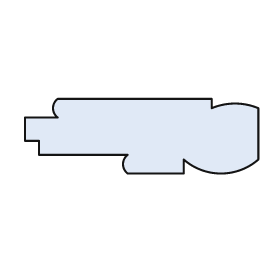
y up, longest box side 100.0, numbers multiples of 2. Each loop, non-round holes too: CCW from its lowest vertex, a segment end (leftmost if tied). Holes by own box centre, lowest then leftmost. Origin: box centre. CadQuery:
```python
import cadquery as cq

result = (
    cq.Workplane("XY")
    .moveTo(-6.0, -16.0)
    .lineTo(18.0, -16.0)
    .lineTo(18.0, -10.0)
    .threePointArc((34.0, -16.0), (50.0, -10.0))
    .lineTo(50.0, 12.0)
    .threePointArc((40.0, 14.0), (30.0, 12.0))
    .lineTo(30.0, 16.0)
    .lineTo(-36.0, 16.0)
    .threePointArc((-38.0, 12.0), (-36.0, 8.0))
    .lineTo(-50.0, 8.0)
    .lineTo(-50.0, -2.0)
    .lineTo(-44.0, -2.0)
    .lineTo(-44.0, -8.0)
    .lineTo(-6.0, -8.0)
    .threePointArc((-8.0, -12.0), (-6.0, -16.0))
    .close()
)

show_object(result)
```